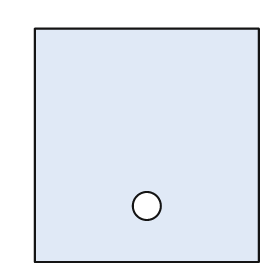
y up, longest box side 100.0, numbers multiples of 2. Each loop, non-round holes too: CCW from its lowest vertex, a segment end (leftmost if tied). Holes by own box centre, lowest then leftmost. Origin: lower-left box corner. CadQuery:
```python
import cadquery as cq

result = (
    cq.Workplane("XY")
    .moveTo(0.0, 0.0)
    .lineTo(96.0, 0.0)
    .lineTo(96.0, 100.0)
    .lineTo(0.0, 100.0)
    .close()
    .moveTo(48.0, 24.0)
    .circle(6.0)
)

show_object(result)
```